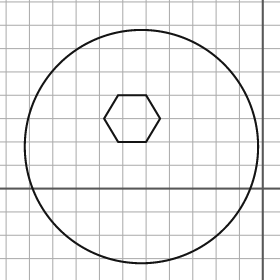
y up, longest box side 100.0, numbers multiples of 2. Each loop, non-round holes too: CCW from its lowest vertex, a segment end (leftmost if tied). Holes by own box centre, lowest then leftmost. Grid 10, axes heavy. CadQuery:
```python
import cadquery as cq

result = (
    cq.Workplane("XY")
    .moveTo(-52.0, 18.0)
    .circle(50.0)
    .moveTo(-62.0, 20.0)
    .lineTo(-50.0, 20.0)
    .lineTo(-44.0, 30.0)
    .lineTo(-50.0, 40.0)
    .lineTo(-62.0, 40.0)
    .lineTo(-68.0, 30.0)
    .close()
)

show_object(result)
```